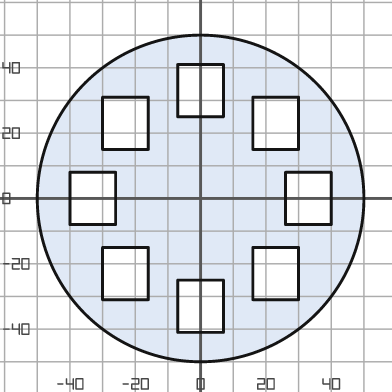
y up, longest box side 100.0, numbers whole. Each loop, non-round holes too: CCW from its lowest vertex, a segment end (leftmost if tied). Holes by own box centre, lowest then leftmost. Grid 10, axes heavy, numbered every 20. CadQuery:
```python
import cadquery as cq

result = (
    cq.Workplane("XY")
    .moveTo(0.0, 0.0)
    .circle(50.0)
    .moveTo(-7.0, -41.0)
    .lineTo(7.0, -41.0)
    .lineTo(7.0, -25.0)
    .lineTo(-7.0, -25.0)
    .close()
    .moveTo(-30.0, -31.0)
    .lineTo(-16.0, -31.0)
    .lineTo(-16.0, -15.0)
    .lineTo(-30.0, -15.0)
    .close()
    .moveTo(16.0, -31.0)
    .lineTo(30.0, -31.0)
    .lineTo(30.0, -15.0)
    .lineTo(16.0, -15.0)
    .close()
    .moveTo(-40.0, -8.0)
    .lineTo(-26.0, -8.0)
    .lineTo(-26.0, 8.0)
    .lineTo(-40.0, 8.0)
    .close()
    .moveTo(26.0, -8.0)
    .lineTo(40.0, -8.0)
    .lineTo(40.0, 8.0)
    .lineTo(26.0, 8.0)
    .close()
    .moveTo(-30.0, 15.0)
    .lineTo(-16.0, 15.0)
    .lineTo(-16.0, 31.0)
    .lineTo(-30.0, 31.0)
    .close()
    .moveTo(16.0, 15.0)
    .lineTo(30.0, 15.0)
    .lineTo(30.0, 31.0)
    .lineTo(16.0, 31.0)
    .close()
    .moveTo(-7.0, 25.0)
    .lineTo(7.0, 25.0)
    .lineTo(7.0, 41.0)
    .lineTo(-7.0, 41.0)
    .close()
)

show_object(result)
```